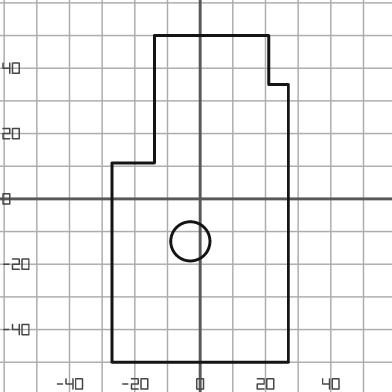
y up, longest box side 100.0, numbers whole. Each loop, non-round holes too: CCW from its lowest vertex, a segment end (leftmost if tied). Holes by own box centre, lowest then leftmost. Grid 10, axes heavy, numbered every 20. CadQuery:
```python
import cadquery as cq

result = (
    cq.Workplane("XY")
    .moveTo(-27.0, -50.0)
    .lineTo(27.0, -50.0)
    .lineTo(27.0, 35.0)
    .lineTo(21.0, 35.0)
    .lineTo(21.0, 50.0)
    .lineTo(-14.0, 50.0)
    .lineTo(-14.0, 11.0)
    .lineTo(-27.0, 11.0)
    .close()
    .moveTo(-3.0, -13.0)
    .circle(6.0)
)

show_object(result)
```